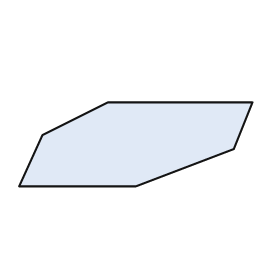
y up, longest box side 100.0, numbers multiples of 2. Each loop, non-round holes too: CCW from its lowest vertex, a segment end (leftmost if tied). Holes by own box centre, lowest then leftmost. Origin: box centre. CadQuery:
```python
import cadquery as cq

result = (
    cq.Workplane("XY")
    .moveTo(-50.0, -18.0)
    .lineTo(0.0, -18.0)
    .lineTo(42.0, -2.0)
    .lineTo(50.0, 18.0)
    .lineTo(-12.0, 18.0)
    .lineTo(-40.0, 4.0)
    .close()
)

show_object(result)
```